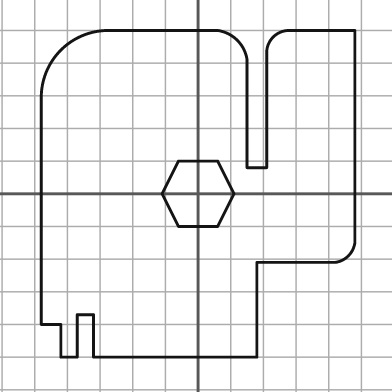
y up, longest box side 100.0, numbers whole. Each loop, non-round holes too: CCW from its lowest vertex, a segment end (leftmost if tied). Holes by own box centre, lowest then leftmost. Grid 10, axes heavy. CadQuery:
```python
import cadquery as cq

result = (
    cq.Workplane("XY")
    .moveTo(-42.0, -50.0)
    .lineTo(-37.0, -50.0)
    .lineTo(-37.0, -37.0)
    .lineTo(-32.0, -37.0)
    .lineTo(-32.0, -50.0)
    .lineTo(18.0, -50.0)
    .lineTo(18.0, -21.0)
    .lineTo(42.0, -21.0)
    .threePointArc((46.0, -19.0), (48.0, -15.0))
    .lineTo(48.0, 50.0)
    .lineTo(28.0, 50.0)
    .threePointArc((23.0, 48.0), (21.0, 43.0))
    .lineTo(21.0, 8.0)
    .lineTo(15.0, 8.0)
    .lineTo(15.0, 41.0)
    .threePointArc((12.0, 47.0), (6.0, 50.0))
    .lineTo(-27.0, 50.0)
    .threePointArc((-42.0, 44.0), (-48.0, 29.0))
    .lineTo(-48.0, -40.0)
    .lineTo(-42.0, -40.0)
    .close()
    .moveTo(-6.0, -10.0)
    .lineTo(6.0, -10.0)
    .lineTo(11.0, 0.0)
    .lineTo(6.0, 10.0)
    .lineTo(-6.0, 10.0)
    .lineTo(-11.0, 0.0)
    .close()
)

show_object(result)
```